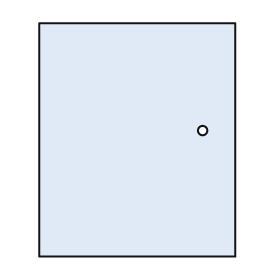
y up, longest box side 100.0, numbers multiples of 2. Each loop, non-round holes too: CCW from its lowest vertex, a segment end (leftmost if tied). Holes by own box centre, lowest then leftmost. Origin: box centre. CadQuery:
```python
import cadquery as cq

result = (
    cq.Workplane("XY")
    .moveTo(-42.0, -50.0)
    .lineTo(42.0, -50.0)
    .lineTo(42.0, 50.0)
    .lineTo(-42.0, 50.0)
    .close()
    .moveTo(28.0, 4.0)
    .circle(2.0)
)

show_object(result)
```